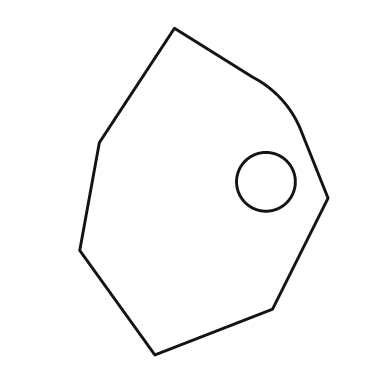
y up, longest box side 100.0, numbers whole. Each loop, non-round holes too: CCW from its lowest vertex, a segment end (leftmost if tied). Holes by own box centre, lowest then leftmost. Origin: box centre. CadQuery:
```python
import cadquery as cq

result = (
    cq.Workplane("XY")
    .moveTo(-15.0, -50.0)
    .lineTo(21.0, -36.0)
    .lineTo(38.0, -2.0)
    .lineTo(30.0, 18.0)
    .threePointArc((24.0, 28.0), (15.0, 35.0))
    .lineTo(-9.0, 50.0)
    .lineTo(-32.0, 15.0)
    .lineTo(-38.0, -18.0)
    .close()
    .moveTo(19.0, 3.0)
    .circle(9.0)
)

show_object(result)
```